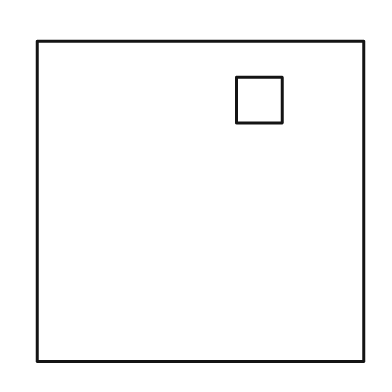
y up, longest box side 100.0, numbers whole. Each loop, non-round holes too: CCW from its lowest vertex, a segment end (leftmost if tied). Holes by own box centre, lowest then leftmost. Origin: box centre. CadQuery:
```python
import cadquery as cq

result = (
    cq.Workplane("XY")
    .moveTo(-50.0, -49.0)
    .lineTo(50.0, -49.0)
    .lineTo(50.0, 49.0)
    .lineTo(-50.0, 49.0)
    .close()
    .moveTo(11.0, 24.0)
    .lineTo(25.0, 24.0)
    .lineTo(25.0, 38.0)
    .lineTo(11.0, 38.0)
    .close()
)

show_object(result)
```